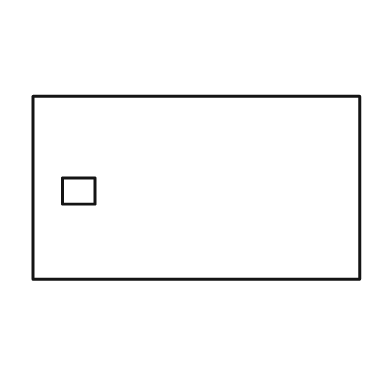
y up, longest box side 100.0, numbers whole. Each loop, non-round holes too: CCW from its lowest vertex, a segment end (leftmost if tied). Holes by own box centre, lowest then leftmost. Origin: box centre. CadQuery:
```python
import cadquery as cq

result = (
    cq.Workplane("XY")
    .moveTo(-50.0, -28.0)
    .lineTo(50.0, -28.0)
    .lineTo(50.0, 28.0)
    .lineTo(-50.0, 28.0)
    .close()
    .moveTo(-41.0, -5.0)
    .lineTo(-31.0, -5.0)
    .lineTo(-31.0, 3.0)
    .lineTo(-41.0, 3.0)
    .close()
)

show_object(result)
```